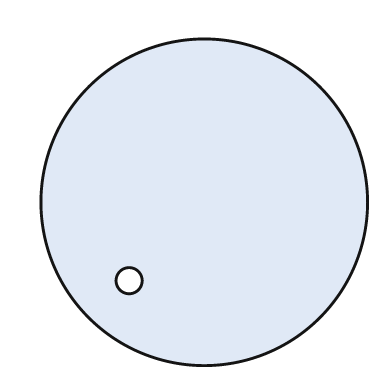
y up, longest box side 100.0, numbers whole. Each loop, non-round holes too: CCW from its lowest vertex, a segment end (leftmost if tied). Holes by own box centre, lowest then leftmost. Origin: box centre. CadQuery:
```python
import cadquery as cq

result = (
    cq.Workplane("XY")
    .moveTo(0.0, 0.0)
    .circle(50.0)
    .moveTo(-23.0, -24.0)
    .circle(4.0)
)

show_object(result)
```